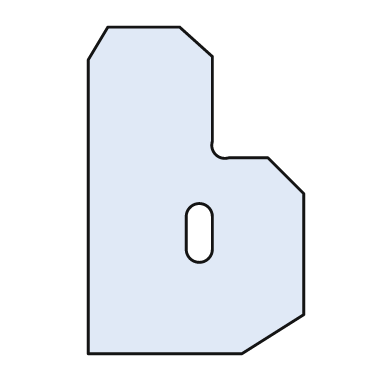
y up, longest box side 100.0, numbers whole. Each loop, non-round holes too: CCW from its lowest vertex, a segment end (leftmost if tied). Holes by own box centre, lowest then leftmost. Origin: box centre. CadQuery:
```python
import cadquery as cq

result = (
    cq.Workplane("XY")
    .moveTo(-33.0, -50.0)
    .lineTo(14.0, -50.0)
    .lineTo(33.0, -38.0)
    .lineTo(33.0, -1.0)
    .lineTo(22.0, 10.0)
    .lineTo(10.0, 10.0)
    .threePointArc((6.0, 11.0), (5.0, 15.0))
    .lineTo(5.0, 41.0)
    .lineTo(-5.0, 50.0)
    .lineTo(-27.0, 50.0)
    .lineTo(-33.0, 40.0)
    .close()
    .moveTo(-3.0, -18.0)
    .threePointArc((1.0, -22.0), (5.0, -18.0))
    .lineTo(5.0, -8.0)
    .threePointArc((1.0, -4.0), (-3.0, -8.0))
    .close()
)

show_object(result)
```